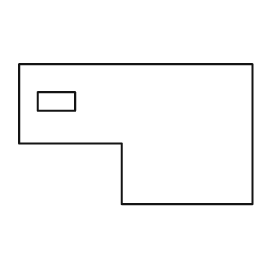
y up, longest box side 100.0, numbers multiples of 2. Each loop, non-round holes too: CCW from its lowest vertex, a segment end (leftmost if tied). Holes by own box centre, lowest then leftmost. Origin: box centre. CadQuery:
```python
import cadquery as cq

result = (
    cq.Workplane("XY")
    .moveTo(-6.0, -30.0)
    .lineTo(50.0, -30.0)
    .lineTo(50.0, 30.0)
    .lineTo(-50.0, 30.0)
    .lineTo(-50.0, -4.0)
    .lineTo(-6.0, -4.0)
    .close()
    .moveTo(-42.0, 10.0)
    .lineTo(-26.0, 10.0)
    .lineTo(-26.0, 18.0)
    .lineTo(-42.0, 18.0)
    .close()
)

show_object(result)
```